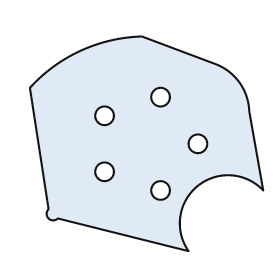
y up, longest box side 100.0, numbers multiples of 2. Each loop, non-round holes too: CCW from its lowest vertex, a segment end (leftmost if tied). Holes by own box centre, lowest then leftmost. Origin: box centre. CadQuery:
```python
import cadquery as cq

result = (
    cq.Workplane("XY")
    .moveTo(18.0, -46.0)
    .threePointArc((22.0, -18.0), (50.0, -20.0))
    .lineTo(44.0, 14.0)
    .threePointArc((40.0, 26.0), (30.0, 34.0))
    .lineTo(-2.0, 46.0)
    .threePointArc((-28.0, 40.0), (-50.0, 24.0))
    .lineTo(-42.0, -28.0)
    .threePointArc((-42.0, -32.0), (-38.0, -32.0))
    .close()
    .moveTo(6.0, -20.0)
    .circle(4.0)
    .moveTo(-18.0, -12.0)
    .circle(4.0)
    .moveTo(22.0, 0.0)
    .circle(4.0)
    .moveTo(-18.0, 12.0)
    .circle(4.0)
    .moveTo(6.0, 20.0)
    .circle(4.0)
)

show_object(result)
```